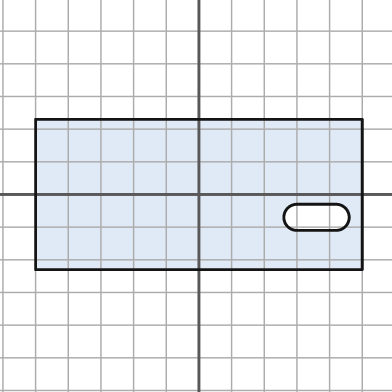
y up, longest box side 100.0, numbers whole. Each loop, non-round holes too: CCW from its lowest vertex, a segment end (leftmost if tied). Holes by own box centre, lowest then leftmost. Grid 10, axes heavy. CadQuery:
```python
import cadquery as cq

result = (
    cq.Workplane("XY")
    .moveTo(-50.0, -23.0)
    .lineTo(50.0, -23.0)
    .lineTo(50.0, 23.0)
    .lineTo(-50.0, 23.0)
    .close()
    .moveTo(30.0, -11.0)
    .lineTo(42.0, -11.0)
    .threePointArc((46.0, -7.0), (42.0, -3.0))
    .lineTo(30.0, -3.0)
    .threePointArc((26.0, -7.0), (30.0, -11.0))
    .close()
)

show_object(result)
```